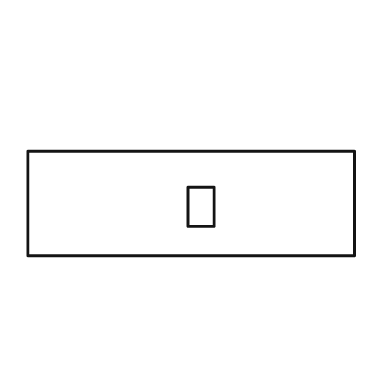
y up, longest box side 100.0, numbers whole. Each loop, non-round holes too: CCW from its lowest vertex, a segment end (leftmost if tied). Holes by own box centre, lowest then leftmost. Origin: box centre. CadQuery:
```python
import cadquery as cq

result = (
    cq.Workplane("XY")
    .moveTo(-50.0, -16.0)
    .lineTo(50.0, -16.0)
    .lineTo(50.0, 16.0)
    .lineTo(-50.0, 16.0)
    .close()
    .moveTo(-1.0, -7.0)
    .lineTo(7.0, -7.0)
    .lineTo(7.0, 5.0)
    .lineTo(-1.0, 5.0)
    .close()
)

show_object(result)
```